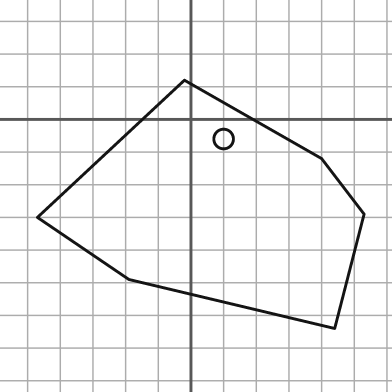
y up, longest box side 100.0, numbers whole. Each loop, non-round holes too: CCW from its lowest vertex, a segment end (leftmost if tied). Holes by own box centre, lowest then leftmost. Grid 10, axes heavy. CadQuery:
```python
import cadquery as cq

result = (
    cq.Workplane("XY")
    .moveTo(44.0, -64.0)
    .lineTo(53.0, -29.0)
    .lineTo(40.0, -12.0)
    .lineTo(-2.0, 12.0)
    .lineTo(-47.0, -30.0)
    .lineTo(-19.0, -49.0)
    .close()
    .moveTo(10.0, -6.0)
    .circle(3.0)
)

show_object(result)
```